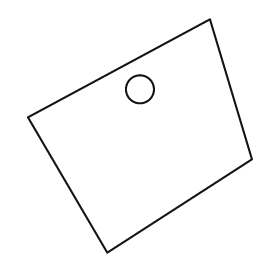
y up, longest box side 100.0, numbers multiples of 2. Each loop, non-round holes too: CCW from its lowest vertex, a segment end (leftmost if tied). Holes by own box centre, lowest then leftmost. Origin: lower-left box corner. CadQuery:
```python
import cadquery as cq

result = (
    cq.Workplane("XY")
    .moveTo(34.0, 0.0)
    .lineTo(96.0, 40.0)
    .lineTo(78.0, 100.0)
    .lineTo(0.0, 58.0)
    .close()
    .moveTo(48.0, 70.0)
    .circle(6.0)
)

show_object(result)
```